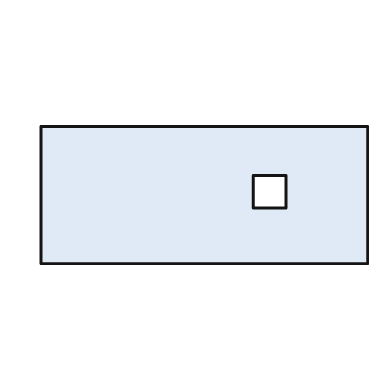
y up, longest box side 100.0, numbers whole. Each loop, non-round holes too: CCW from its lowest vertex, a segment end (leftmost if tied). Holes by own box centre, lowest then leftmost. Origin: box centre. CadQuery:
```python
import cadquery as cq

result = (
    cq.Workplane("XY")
    .moveTo(-50.0, -21.0)
    .lineTo(50.0, -21.0)
    .lineTo(50.0, 21.0)
    .lineTo(-50.0, 21.0)
    .close()
    .moveTo(15.0, -4.0)
    .lineTo(25.0, -4.0)
    .lineTo(25.0, 6.0)
    .lineTo(15.0, 6.0)
    .close()
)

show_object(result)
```